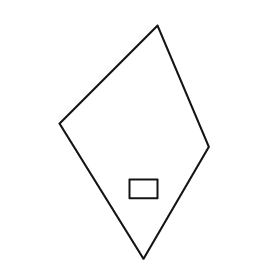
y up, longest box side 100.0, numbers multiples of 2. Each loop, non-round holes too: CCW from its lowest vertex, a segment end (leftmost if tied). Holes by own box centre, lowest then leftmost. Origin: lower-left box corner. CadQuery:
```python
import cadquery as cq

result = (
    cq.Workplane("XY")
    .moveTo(36.0, 0.0)
    .lineTo(64.0, 48.0)
    .lineTo(42.0, 100.0)
    .lineTo(0.0, 58.0)
    .close()
    .moveTo(30.0, 26.0)
    .lineTo(42.0, 26.0)
    .lineTo(42.0, 34.0)
    .lineTo(30.0, 34.0)
    .close()
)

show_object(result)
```